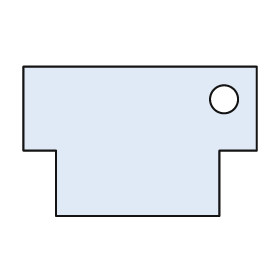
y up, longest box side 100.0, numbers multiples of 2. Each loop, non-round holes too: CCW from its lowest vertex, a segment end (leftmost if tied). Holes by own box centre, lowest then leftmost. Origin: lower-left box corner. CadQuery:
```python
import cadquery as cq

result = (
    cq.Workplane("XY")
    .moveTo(14.0, 0.0)
    .lineTo(84.0, 0.0)
    .lineTo(84.0, 28.0)
    .lineTo(100.0, 28.0)
    .lineTo(100.0, 64.0)
    .lineTo(0.0, 64.0)
    .lineTo(0.0, 28.0)
    .lineTo(14.0, 28.0)
    .close()
    .moveTo(86.0, 50.0)
    .circle(6.0)
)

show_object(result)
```